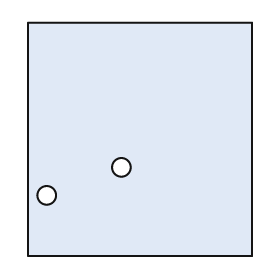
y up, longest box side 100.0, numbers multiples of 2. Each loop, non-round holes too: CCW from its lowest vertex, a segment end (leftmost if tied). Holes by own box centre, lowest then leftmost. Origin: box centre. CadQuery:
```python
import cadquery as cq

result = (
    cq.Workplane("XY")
    .moveTo(-48.0, -50.0)
    .lineTo(48.0, -50.0)
    .lineTo(48.0, 50.0)
    .lineTo(-48.0, 50.0)
    .close()
    .moveTo(-40.0, -24.0)
    .circle(4.0)
    .moveTo(-8.0, -12.0)
    .circle(4.0)
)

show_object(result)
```